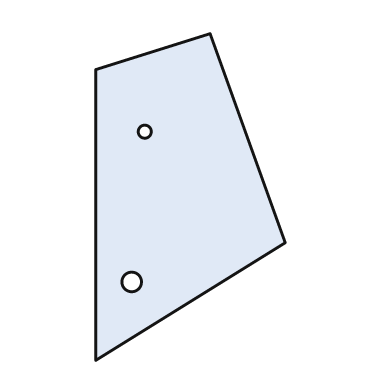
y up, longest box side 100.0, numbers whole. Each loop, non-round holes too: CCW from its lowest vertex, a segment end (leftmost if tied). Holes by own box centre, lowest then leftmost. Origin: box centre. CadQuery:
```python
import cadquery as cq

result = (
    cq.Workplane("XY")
    .moveTo(-29.0, -50.0)
    .lineTo(29.0, -14.0)
    .lineTo(6.0, 50.0)
    .lineTo(-29.0, 39.0)
    .close()
    .moveTo(-18.0, -26.0)
    .circle(3.0)
    .moveTo(-14.0, 20.0)
    .circle(2.0)
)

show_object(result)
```